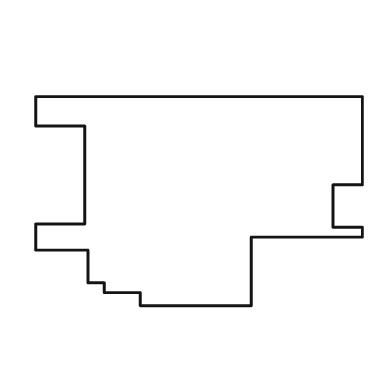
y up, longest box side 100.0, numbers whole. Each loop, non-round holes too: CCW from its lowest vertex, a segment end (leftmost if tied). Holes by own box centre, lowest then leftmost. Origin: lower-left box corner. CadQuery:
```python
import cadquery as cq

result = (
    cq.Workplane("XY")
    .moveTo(32.0, 0.0)
    .lineTo(66.0, 0.0)
    .lineTo(66.0, 21.0)
    .lineTo(100.0, 21.0)
    .lineTo(100.0, 24.0)
    .lineTo(91.0, 24.0)
    .lineTo(91.0, 37.0)
    .lineTo(100.0, 37.0)
    .lineTo(100.0, 64.0)
    .lineTo(0.0, 64.0)
    .lineTo(0.0, 55.0)
    .lineTo(15.0, 55.0)
    .lineTo(15.0, 25.0)
    .lineTo(0.0, 25.0)
    .lineTo(0.0, 17.0)
    .lineTo(16.0, 17.0)
    .lineTo(16.0, 7.0)
    .lineTo(21.0, 7.0)
    .lineTo(21.0, 4.0)
    .lineTo(32.0, 4.0)
    .close()
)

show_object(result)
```